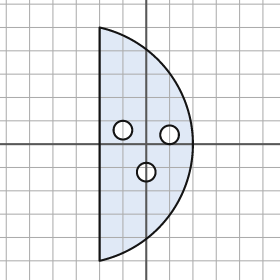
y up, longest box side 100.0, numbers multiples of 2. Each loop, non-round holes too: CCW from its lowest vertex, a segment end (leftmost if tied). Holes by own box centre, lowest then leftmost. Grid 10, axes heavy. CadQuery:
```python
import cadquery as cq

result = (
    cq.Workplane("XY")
    .moveTo(-20.0, -50.0)
    .threePointArc((20.0, 0.0), (-20.0, 50.0))
    .close()
    .moveTo(0.0, -12.0)
    .circle(4.0)
    .moveTo(10.0, 4.0)
    .circle(4.0)
    .moveTo(-10.0, 6.0)
    .circle(4.0)
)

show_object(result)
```